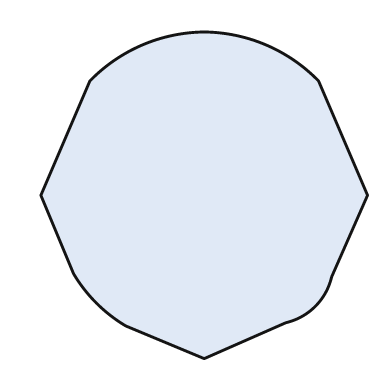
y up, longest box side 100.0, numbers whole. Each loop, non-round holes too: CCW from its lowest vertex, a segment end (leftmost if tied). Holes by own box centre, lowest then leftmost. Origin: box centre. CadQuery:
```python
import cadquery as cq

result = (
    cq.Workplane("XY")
    .moveTo(0.0, -50.0)
    .lineTo(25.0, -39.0)
    .threePointArc((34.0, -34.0), (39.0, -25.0))
    .lineTo(50.0, 0.0)
    .lineTo(35.0, 35.0)
    .threePointArc((19.0, 46.0), (0.0, 50.0))
    .threePointArc((-19.0, 46.0), (-35.0, 35.0))
    .lineTo(-50.0, 0.0)
    .lineTo(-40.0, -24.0)
    .threePointArc((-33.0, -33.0), (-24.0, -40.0))
    .close()
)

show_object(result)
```